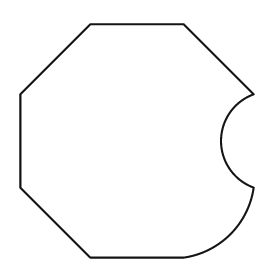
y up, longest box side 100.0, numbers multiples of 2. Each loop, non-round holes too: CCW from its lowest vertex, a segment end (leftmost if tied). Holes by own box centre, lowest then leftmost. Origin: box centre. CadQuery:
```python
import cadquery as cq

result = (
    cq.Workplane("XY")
    .moveTo(-20.0, -50.0)
    .lineTo(20.0, -50.0)
    .threePointArc((40.0, -40.0), (50.0, -20.0))
    .threePointArc((36.0, 0.0), (50.0, 20.0))
    .lineTo(20.0, 50.0)
    .lineTo(-20.0, 50.0)
    .lineTo(-50.0, 20.0)
    .lineTo(-50.0, -20.0)
    .close()
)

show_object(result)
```